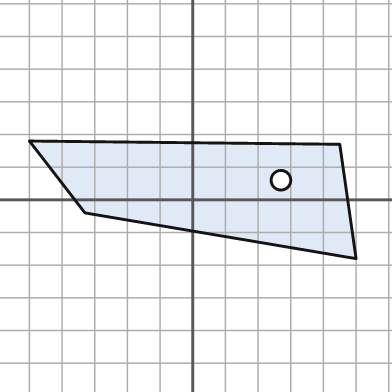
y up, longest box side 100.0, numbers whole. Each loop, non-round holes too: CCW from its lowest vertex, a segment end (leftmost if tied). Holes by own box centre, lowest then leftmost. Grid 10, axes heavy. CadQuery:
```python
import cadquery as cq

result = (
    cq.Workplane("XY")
    .moveTo(50.0, -18.0)
    .lineTo(45.0, 17.0)
    .lineTo(-50.0, 18.0)
    .lineTo(-33.0, -4.0)
    .close()
    .moveTo(27.0, 6.0)
    .circle(3.0)
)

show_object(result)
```